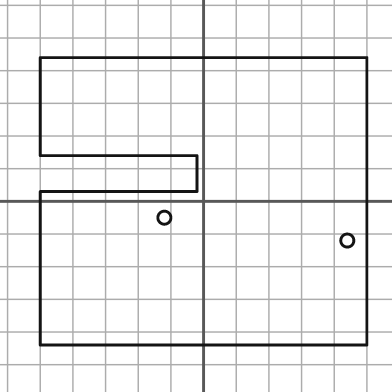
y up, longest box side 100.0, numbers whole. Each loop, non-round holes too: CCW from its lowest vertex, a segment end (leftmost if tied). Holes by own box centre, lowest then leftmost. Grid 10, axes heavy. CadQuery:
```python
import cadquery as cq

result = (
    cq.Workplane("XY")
    .moveTo(-50.0, -44.0)
    .lineTo(50.0, -44.0)
    .lineTo(50.0, 44.0)
    .lineTo(-50.0, 44.0)
    .lineTo(-50.0, 14.0)
    .lineTo(-2.0, 14.0)
    .lineTo(-2.0, 3.0)
    .lineTo(-50.0, 3.0)
    .close()
    .moveTo(44.0, -12.0)
    .circle(2.0)
    .moveTo(-12.0, -5.0)
    .circle(2.0)
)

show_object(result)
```